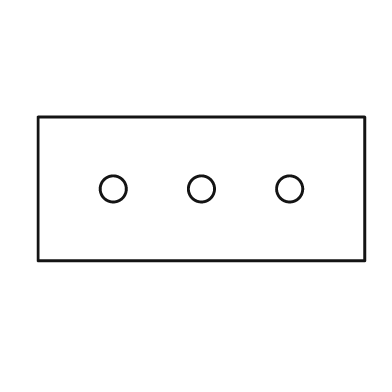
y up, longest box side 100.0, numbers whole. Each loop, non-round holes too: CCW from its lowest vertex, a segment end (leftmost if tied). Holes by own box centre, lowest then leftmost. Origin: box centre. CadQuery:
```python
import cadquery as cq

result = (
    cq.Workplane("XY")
    .moveTo(-50.0, -22.0)
    .lineTo(50.0, -22.0)
    .lineTo(50.0, 22.0)
    .lineTo(-50.0, 22.0)
    .close()
    .moveTo(-27.0, 0.0)
    .circle(4.0)
    .moveTo(0.0, 0.0)
    .circle(4.0)
    .moveTo(27.0, 0.0)
    .circle(4.0)
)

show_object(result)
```